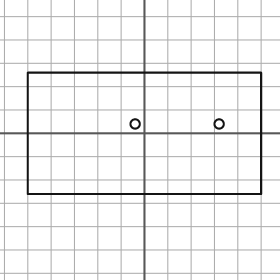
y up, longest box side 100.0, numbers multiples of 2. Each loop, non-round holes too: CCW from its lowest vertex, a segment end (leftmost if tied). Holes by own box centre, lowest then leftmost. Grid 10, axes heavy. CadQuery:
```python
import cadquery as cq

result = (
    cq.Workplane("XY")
    .moveTo(-50.0, -26.0)
    .lineTo(50.0, -26.0)
    .lineTo(50.0, 26.0)
    .lineTo(-50.0, 26.0)
    .close()
    .moveTo(-4.0, 4.0)
    .circle(2.0)
    .moveTo(32.0, 4.0)
    .circle(2.0)
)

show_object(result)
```